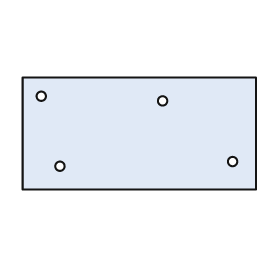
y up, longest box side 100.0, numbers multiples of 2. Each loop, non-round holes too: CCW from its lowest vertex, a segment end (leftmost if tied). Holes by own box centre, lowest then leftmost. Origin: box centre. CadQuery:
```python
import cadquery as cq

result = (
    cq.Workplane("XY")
    .moveTo(-50.0, -24.0)
    .lineTo(50.0, -24.0)
    .lineTo(50.0, 24.0)
    .lineTo(-50.0, 24.0)
    .close()
    .moveTo(-34.0, -14.0)
    .circle(2.0)
    .moveTo(40.0, -12.0)
    .circle(2.0)
    .moveTo(10.0, 14.0)
    .circle(2.0)
    .moveTo(-42.0, 16.0)
    .circle(2.0)
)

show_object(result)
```